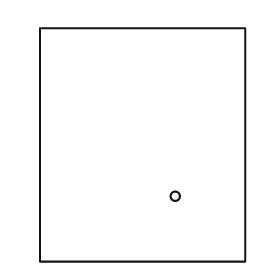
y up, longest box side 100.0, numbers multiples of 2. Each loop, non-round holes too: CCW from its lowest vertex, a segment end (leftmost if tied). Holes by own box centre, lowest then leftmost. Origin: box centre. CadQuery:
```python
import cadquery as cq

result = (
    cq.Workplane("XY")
    .moveTo(-44.0, -50.0)
    .lineTo(44.0, -50.0)
    .lineTo(44.0, 50.0)
    .lineTo(-44.0, 50.0)
    .close()
    .moveTo(14.0, -22.0)
    .circle(2.0)
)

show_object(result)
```